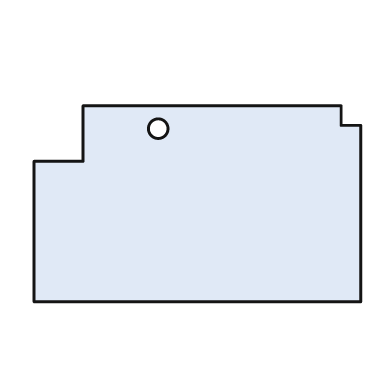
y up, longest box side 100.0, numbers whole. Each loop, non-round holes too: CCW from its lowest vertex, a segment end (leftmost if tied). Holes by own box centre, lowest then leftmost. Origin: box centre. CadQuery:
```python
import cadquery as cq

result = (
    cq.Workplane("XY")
    .moveTo(-50.0, -30.0)
    .lineTo(50.0, -30.0)
    .lineTo(50.0, 24.0)
    .lineTo(44.0, 24.0)
    .lineTo(44.0, 30.0)
    .lineTo(-35.0, 30.0)
    .lineTo(-35.0, 13.0)
    .lineTo(-50.0, 13.0)
    .close()
    .moveTo(-12.0, 23.0)
    .circle(3.0)
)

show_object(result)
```